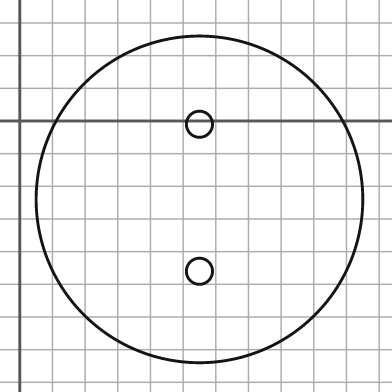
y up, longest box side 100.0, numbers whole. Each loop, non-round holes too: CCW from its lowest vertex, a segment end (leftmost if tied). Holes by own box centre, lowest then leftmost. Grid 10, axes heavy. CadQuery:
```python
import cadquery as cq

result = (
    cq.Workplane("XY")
    .moveTo(55.0, -24.0)
    .circle(50.0)
    .moveTo(55.0, -46.0)
    .circle(4.0)
    .moveTo(55.0, -1.0)
    .circle(4.0)
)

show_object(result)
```